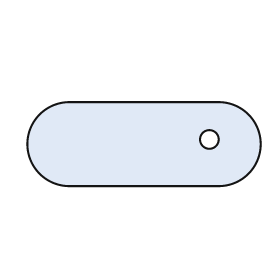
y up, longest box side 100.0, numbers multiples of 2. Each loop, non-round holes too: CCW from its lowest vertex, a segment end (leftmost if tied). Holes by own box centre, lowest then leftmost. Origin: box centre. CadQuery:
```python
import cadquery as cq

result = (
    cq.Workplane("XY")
    .moveTo(-32.0, -18.0)
    .lineTo(32.0, -18.0)
    .threePointArc((50.0, 0.0), (32.0, 18.0))
    .lineTo(-32.0, 18.0)
    .threePointArc((-50.0, 0.0), (-32.0, -18.0))
    .close()
    .moveTo(28.0, 2.0)
    .circle(4.0)
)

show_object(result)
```